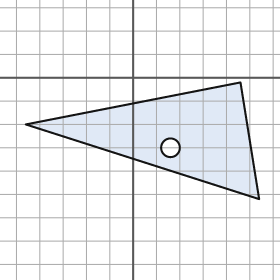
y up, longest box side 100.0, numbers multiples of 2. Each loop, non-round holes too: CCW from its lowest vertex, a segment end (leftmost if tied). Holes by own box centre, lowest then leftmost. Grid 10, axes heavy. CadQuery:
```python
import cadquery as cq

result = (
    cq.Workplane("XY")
    .moveTo(54.0, -52.0)
    .lineTo(46.0, -2.0)
    .lineTo(-46.0, -20.0)
    .close()
    .moveTo(16.0, -30.0)
    .circle(4.0)
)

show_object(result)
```